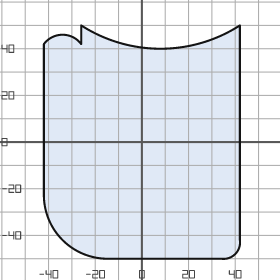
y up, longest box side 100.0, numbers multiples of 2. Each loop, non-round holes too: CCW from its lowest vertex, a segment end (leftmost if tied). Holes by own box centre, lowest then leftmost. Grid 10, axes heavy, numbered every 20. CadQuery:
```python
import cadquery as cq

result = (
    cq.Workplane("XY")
    .moveTo(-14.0, -50.0)
    .lineTo(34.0, -50.0)
    .threePointArc((40.0, -48.0), (42.0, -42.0))
    .lineTo(42.0, 50.0)
    .threePointArc((8.0, 40.0), (-26.0, 50.0))
    .lineTo(-26.0, 42.0)
    .threePointArc((-34.0, 46.0), (-42.0, 42.0))
    .lineTo(-42.0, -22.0)
    .threePointArc((-34.0, -42.0), (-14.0, -50.0))
    .close()
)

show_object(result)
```